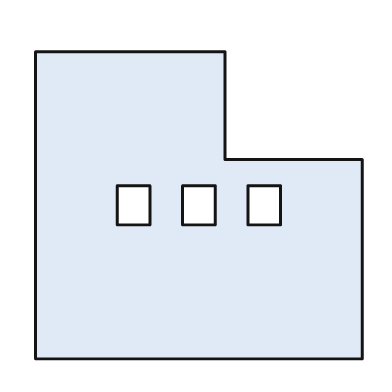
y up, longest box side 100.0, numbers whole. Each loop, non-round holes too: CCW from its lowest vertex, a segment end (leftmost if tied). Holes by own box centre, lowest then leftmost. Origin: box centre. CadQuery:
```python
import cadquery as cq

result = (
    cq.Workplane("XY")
    .moveTo(-50.0, -47.0)
    .lineTo(50.0, -47.0)
    .lineTo(50.0, 14.0)
    .lineTo(8.0, 14.0)
    .lineTo(8.0, 47.0)
    .lineTo(-50.0, 47.0)
    .close()
    .moveTo(-25.0, -6.0)
    .lineTo(-15.0, -6.0)
    .lineTo(-15.0, 6.0)
    .lineTo(-25.0, 6.0)
    .close()
    .moveTo(-5.0, -6.0)
    .lineTo(5.0, -6.0)
    .lineTo(5.0, 6.0)
    .lineTo(-5.0, 6.0)
    .close()
    .moveTo(15.0, -6.0)
    .lineTo(25.0, -6.0)
    .lineTo(25.0, 6.0)
    .lineTo(15.0, 6.0)
    .close()
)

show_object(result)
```